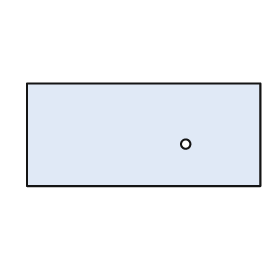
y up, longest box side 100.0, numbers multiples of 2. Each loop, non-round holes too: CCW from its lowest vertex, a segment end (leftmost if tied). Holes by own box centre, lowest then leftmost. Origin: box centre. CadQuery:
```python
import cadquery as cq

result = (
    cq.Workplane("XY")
    .moveTo(-50.0, -22.0)
    .lineTo(50.0, -22.0)
    .lineTo(50.0, 22.0)
    .lineTo(-50.0, 22.0)
    .close()
    .moveTo(18.0, -4.0)
    .circle(2.0)
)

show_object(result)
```